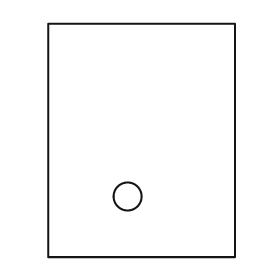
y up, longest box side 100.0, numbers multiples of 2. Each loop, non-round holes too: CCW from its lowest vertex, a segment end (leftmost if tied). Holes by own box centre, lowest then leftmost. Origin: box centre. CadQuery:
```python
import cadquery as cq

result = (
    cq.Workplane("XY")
    .moveTo(-40.0, -50.0)
    .lineTo(40.0, -50.0)
    .lineTo(40.0, 50.0)
    .lineTo(-40.0, 50.0)
    .close()
    .moveTo(-6.0, -24.0)
    .circle(6.0)
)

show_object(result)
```